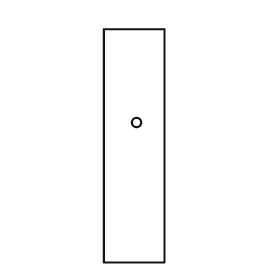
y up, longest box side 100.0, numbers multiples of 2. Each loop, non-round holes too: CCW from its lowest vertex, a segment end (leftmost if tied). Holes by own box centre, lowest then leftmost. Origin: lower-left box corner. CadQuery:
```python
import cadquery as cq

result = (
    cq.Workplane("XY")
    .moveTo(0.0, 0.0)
    .lineTo(26.0, 0.0)
    .lineTo(26.0, 100.0)
    .lineTo(0.0, 100.0)
    .close()
    .moveTo(14.0, 60.0)
    .circle(2.0)
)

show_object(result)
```